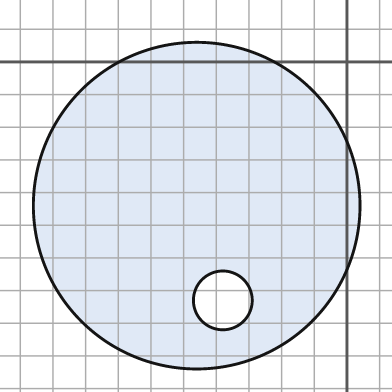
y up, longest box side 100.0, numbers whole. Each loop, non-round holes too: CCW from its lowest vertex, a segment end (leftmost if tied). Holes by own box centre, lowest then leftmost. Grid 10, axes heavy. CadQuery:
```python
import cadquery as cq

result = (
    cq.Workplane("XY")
    .moveTo(-46.0, -44.0)
    .circle(50.0)
    .moveTo(-38.0, -73.0)
    .circle(9.0)
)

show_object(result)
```